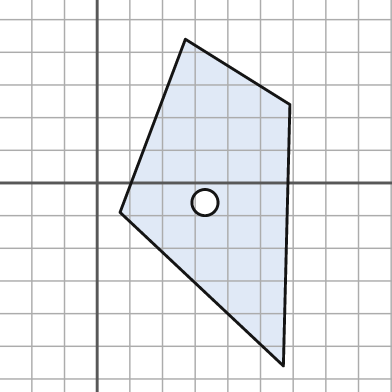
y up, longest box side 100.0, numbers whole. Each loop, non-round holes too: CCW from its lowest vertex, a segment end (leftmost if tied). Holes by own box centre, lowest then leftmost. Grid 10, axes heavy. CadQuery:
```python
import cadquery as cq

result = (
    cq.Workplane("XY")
    .moveTo(57.0, -56.0)
    .lineTo(59.0, 24.0)
    .lineTo(27.0, 44.0)
    .lineTo(7.0, -9.0)
    .close()
    .moveTo(33.0, -6.0)
    .circle(4.0)
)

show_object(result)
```